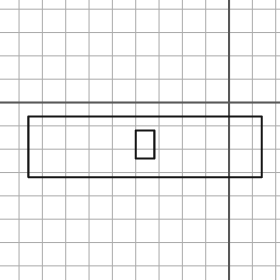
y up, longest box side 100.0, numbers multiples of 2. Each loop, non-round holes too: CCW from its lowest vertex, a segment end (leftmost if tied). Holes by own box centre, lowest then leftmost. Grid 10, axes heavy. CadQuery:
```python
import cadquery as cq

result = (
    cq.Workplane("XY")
    .moveTo(-86.0, -32.0)
    .lineTo(14.0, -32.0)
    .lineTo(14.0, -6.0)
    .lineTo(-86.0, -6.0)
    .close()
    .moveTo(-40.0, -24.0)
    .lineTo(-32.0, -24.0)
    .lineTo(-32.0, -12.0)
    .lineTo(-40.0, -12.0)
    .close()
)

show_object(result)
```